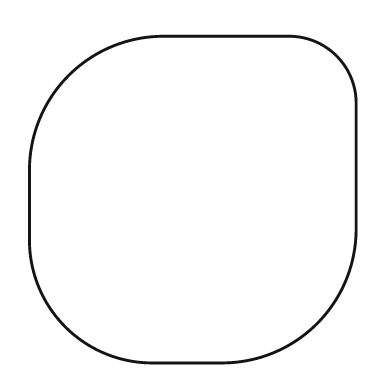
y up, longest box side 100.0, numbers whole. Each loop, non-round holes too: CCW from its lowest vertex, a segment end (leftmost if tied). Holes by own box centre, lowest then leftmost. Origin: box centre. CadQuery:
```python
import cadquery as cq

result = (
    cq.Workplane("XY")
    .moveTo(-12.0, -50.0)
    .lineTo(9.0, -50.0)
    .threePointArc((38.0, -38.0), (50.0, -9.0))
    .lineTo(50.0, 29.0)
    .threePointArc((44.0, 44.0), (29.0, 50.0))
    .lineTo(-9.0, 50.0)
    .threePointArc((-38.0, 38.0), (-50.0, 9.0))
    .lineTo(-50.0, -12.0)
    .threePointArc((-39.0, -39.0), (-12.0, -50.0))
    .close()
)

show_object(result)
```